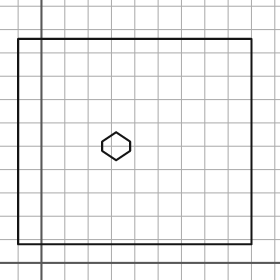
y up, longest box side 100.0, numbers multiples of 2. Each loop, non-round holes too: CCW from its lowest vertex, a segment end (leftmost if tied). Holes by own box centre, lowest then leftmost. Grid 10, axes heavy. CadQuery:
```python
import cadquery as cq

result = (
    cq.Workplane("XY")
    .moveTo(-10.0, 8.0)
    .lineTo(90.0, 8.0)
    .lineTo(90.0, 96.0)
    .lineTo(-10.0, 96.0)
    .close()
    .moveTo(32.0, 44.0)
    .lineTo(38.0, 48.0)
    .lineTo(38.0, 52.0)
    .lineTo(32.0, 56.0)
    .lineTo(26.0, 52.0)
    .lineTo(26.0, 48.0)
    .close()
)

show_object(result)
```